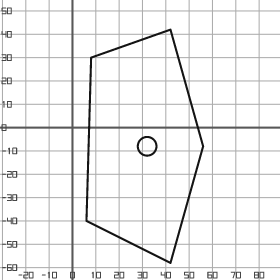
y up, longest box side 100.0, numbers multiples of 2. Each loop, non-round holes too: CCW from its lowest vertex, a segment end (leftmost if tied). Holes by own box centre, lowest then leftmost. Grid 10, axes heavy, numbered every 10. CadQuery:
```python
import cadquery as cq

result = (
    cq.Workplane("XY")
    .moveTo(42.0, -58.0)
    .lineTo(56.0, -8.0)
    .lineTo(42.0, 42.0)
    .lineTo(8.0, 30.0)
    .lineTo(6.0, -40.0)
    .close()
    .moveTo(32.0, -8.0)
    .circle(4.0)
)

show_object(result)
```